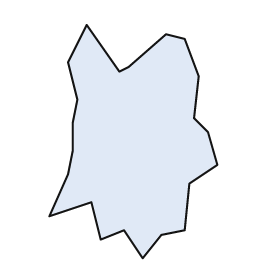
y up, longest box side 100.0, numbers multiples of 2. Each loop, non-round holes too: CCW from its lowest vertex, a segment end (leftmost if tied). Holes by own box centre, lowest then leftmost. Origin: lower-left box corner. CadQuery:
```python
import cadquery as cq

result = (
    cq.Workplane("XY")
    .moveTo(40.0, 0.0)
    .lineTo(48.0, 10.0)
    .lineTo(58.0, 12.0)
    .lineTo(60.0, 32.0)
    .lineTo(72.0, 40.0)
    .lineTo(68.0, 54.0)
    .lineTo(62.0, 60.0)
    .lineTo(64.0, 78.0)
    .lineTo(58.0, 94.0)
    .lineTo(50.0, 96.0)
    .lineTo(34.0, 82.0)
    .lineTo(30.0, 80.0)
    .lineTo(16.0, 100.0)
    .lineTo(8.0, 84.0)
    .lineTo(12.0, 68.0)
    .lineTo(10.0, 58.0)
    .lineTo(10.0, 46.0)
    .lineTo(8.0, 36.0)
    .lineTo(0.0, 18.0)
    .lineTo(18.0, 24.0)
    .lineTo(22.0, 8.0)
    .lineTo(32.0, 12.0)
    .close()
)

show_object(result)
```